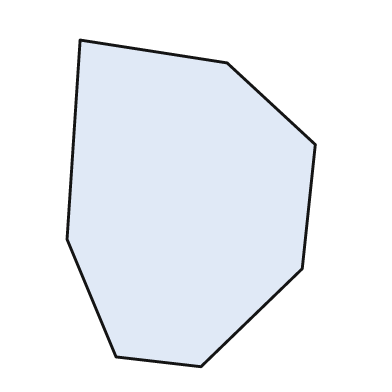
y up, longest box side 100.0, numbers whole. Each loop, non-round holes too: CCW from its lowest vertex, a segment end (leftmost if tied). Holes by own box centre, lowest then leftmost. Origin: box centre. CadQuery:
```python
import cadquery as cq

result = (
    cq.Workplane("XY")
    .moveTo(3.0, -50.0)
    .lineTo(34.0, -20.0)
    .lineTo(38.0, 18.0)
    .lineTo(11.0, 43.0)
    .lineTo(-34.0, 50.0)
    .lineTo(-38.0, -11.0)
    .lineTo(-23.0, -47.0)
    .close()
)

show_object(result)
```